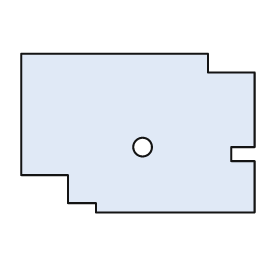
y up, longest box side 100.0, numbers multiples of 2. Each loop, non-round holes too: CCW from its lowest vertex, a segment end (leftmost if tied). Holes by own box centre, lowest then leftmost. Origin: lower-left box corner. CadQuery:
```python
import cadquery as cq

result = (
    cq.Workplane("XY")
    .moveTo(32.0, 0.0)
    .lineTo(100.0, 0.0)
    .lineTo(100.0, 22.0)
    .lineTo(90.0, 22.0)
    .lineTo(90.0, 28.0)
    .lineTo(100.0, 28.0)
    .lineTo(100.0, 60.0)
    .lineTo(80.0, 60.0)
    .lineTo(80.0, 68.0)
    .lineTo(0.0, 68.0)
    .lineTo(0.0, 16.0)
    .lineTo(20.0, 16.0)
    .lineTo(20.0, 4.0)
    .lineTo(32.0, 4.0)
    .close()
    .moveTo(52.0, 28.0)
    .circle(4.0)
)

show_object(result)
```